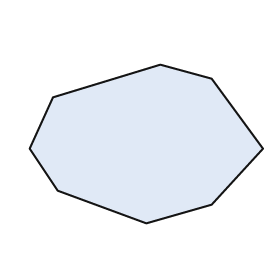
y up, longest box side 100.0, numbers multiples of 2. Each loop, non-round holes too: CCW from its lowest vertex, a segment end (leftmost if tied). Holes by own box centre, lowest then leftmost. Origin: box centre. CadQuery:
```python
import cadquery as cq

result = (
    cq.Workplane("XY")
    .moveTo(0.0, -34.0)
    .lineTo(28.0, -26.0)
    .lineTo(50.0, -2.0)
    .lineTo(28.0, 28.0)
    .lineTo(6.0, 34.0)
    .lineTo(-40.0, 20.0)
    .lineTo(-50.0, -2.0)
    .lineTo(-38.0, -20.0)
    .close()
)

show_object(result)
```